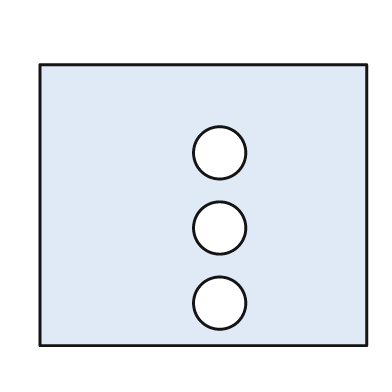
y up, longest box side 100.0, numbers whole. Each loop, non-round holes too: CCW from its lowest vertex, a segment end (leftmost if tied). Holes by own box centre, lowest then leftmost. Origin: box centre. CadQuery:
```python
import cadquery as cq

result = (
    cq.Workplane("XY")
    .moveTo(-50.0, -43.0)
    .lineTo(50.0, -43.0)
    .lineTo(50.0, 43.0)
    .lineTo(-50.0, 43.0)
    .close()
    .moveTo(5.0, -30.0)
    .circle(8.0)
    .moveTo(5.0, -7.0)
    .circle(8.0)
    .moveTo(5.0, 16.0)
    .circle(8.0)
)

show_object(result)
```